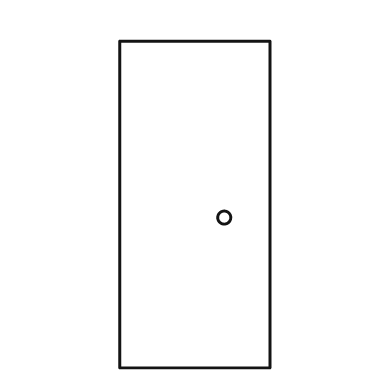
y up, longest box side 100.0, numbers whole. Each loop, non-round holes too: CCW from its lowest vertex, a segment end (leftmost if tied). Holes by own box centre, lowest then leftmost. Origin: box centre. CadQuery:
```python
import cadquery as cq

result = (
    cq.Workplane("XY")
    .moveTo(-23.0, -50.0)
    .lineTo(23.0, -50.0)
    .lineTo(23.0, 50.0)
    .lineTo(-23.0, 50.0)
    .close()
    .moveTo(9.0, -4.0)
    .circle(2.0)
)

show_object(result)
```